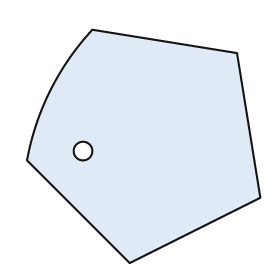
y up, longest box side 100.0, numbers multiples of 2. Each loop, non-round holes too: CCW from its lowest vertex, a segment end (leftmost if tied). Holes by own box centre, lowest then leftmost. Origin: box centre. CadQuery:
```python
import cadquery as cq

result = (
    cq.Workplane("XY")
    .moveTo(-6.0, -50.0)
    .lineTo(50.0, -22.0)
    .lineTo(40.0, 40.0)
    .lineTo(-22.0, 50.0)
    .threePointArc((-40.0, 24.0), (-50.0, -6.0))
    .close()
    .moveTo(-26.0, -2.0)
    .circle(4.0)
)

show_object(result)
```